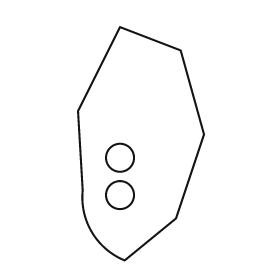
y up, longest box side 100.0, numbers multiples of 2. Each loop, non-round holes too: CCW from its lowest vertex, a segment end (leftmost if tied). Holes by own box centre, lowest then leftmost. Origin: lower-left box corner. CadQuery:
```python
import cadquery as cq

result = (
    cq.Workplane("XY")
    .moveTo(20.0, 0.0)
    .lineTo(42.0, 18.0)
    .lineTo(54.0, 54.0)
    .lineTo(44.0, 90.0)
    .lineTo(18.0, 100.0)
    .lineTo(0.0, 64.0)
    .lineTo(2.0, 30.0)
    .threePointArc((6.0, 12.0), (20.0, 0.0))
    .close()
    .moveTo(18.0, 28.0)
    .circle(6.0)
    .moveTo(18.0, 44.0)
    .circle(6.0)
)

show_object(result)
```